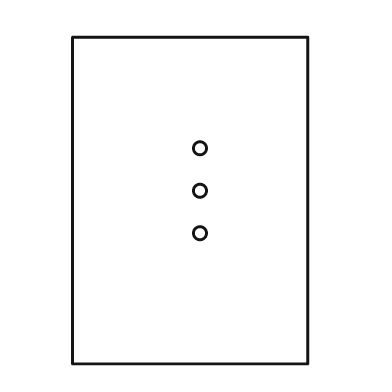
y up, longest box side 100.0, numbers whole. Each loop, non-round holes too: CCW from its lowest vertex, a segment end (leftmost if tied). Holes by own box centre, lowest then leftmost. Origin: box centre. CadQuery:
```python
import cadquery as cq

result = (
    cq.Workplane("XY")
    .moveTo(-36.0, -50.0)
    .lineTo(36.0, -50.0)
    .lineTo(36.0, 50.0)
    .lineTo(-36.0, 50.0)
    .close()
    .moveTo(3.0, -10.0)
    .circle(2.0)
    .moveTo(3.0, 3.0)
    .circle(2.0)
    .moveTo(3.0, 16.0)
    .circle(2.0)
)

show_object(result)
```